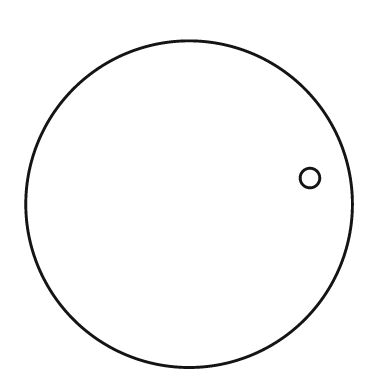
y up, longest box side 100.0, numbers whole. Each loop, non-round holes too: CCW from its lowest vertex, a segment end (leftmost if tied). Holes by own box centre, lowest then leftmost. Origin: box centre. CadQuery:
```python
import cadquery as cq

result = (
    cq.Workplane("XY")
    .moveTo(0.0, 0.0)
    .circle(50.0)
    .moveTo(37.0, 8.0)
    .circle(3.0)
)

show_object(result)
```